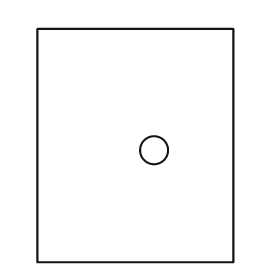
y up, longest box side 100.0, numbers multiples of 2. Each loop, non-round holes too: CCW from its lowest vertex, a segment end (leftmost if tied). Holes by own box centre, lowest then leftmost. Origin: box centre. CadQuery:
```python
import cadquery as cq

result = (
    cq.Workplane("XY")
    .moveTo(-42.0, -50.0)
    .lineTo(42.0, -50.0)
    .lineTo(42.0, 50.0)
    .lineTo(-42.0, 50.0)
    .close()
    .moveTo(8.0, -2.0)
    .circle(6.0)
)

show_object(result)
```